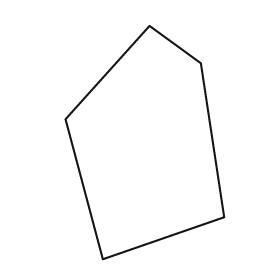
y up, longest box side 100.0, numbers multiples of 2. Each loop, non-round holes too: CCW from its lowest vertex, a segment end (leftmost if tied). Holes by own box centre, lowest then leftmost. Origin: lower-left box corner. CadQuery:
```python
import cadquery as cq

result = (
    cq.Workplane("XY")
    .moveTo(16.0, 0.0)
    .lineTo(68.0, 18.0)
    .lineTo(58.0, 84.0)
    .lineTo(36.0, 100.0)
    .lineTo(0.0, 60.0)
    .close()
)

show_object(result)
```